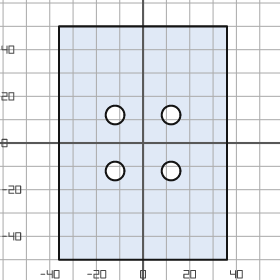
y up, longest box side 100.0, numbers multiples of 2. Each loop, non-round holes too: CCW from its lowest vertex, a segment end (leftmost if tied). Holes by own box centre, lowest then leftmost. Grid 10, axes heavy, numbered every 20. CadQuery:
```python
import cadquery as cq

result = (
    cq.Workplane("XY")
    .moveTo(-36.0, -50.0)
    .lineTo(36.0, -50.0)
    .lineTo(36.0, 50.0)
    .lineTo(-36.0, 50.0)
    .close()
    .moveTo(-12.0, -12.0)
    .circle(4.0)
    .moveTo(12.0, -12.0)
    .circle(4.0)
    .moveTo(-12.0, 12.0)
    .circle(4.0)
    .moveTo(12.0, 12.0)
    .circle(4.0)
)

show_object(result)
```